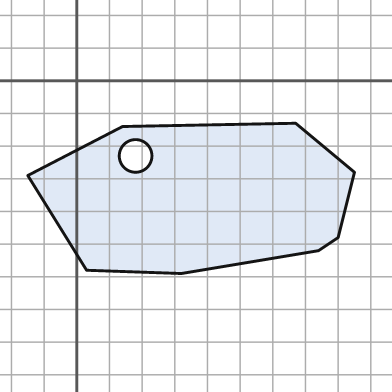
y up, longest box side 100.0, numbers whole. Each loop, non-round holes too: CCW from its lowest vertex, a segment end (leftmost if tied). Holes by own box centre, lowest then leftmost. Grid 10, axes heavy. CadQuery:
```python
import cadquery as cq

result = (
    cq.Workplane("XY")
    .moveTo(32.0, -59.0)
    .lineTo(74.0, -52.0)
    .lineTo(80.0, -48.0)
    .lineTo(85.0, -28.0)
    .lineTo(67.0, -13.0)
    .lineTo(14.0, -14.0)
    .lineTo(-15.0, -29.0)
    .lineTo(3.0, -58.0)
    .close()
    .moveTo(18.0, -23.0)
    .circle(5.0)
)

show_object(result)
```